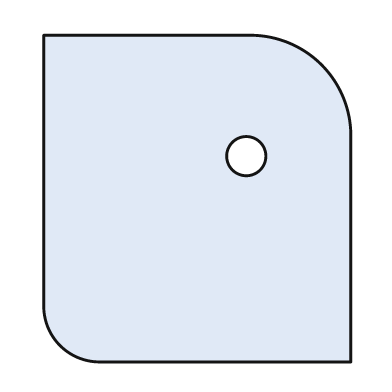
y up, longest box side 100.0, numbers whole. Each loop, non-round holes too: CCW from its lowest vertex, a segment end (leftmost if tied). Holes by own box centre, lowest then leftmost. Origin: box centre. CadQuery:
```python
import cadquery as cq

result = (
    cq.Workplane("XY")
    .moveTo(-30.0, -50.0)
    .lineTo(47.0, -50.0)
    .lineTo(47.0, 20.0)
    .threePointArc((38.0, 41.0), (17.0, 50.0))
    .lineTo(-47.0, 50.0)
    .lineTo(-47.0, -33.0)
    .threePointArc((-42.0, -45.0), (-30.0, -50.0))
    .close()
    .moveTo(15.0, 13.0)
    .circle(6.0)
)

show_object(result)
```